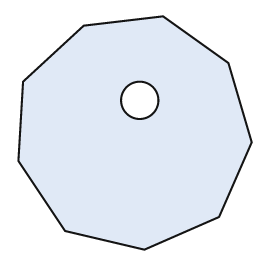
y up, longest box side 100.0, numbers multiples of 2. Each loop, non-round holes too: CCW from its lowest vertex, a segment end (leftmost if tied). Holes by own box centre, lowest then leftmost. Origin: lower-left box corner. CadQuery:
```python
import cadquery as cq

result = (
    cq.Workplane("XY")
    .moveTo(54.0, 0.0)
    .lineTo(86.0, 14.0)
    .lineTo(100.0, 46.0)
    .lineTo(90.0, 80.0)
    .lineTo(62.0, 100.0)
    .lineTo(28.0, 96.0)
    .lineTo(2.0, 72.0)
    .lineTo(0.0, 38.0)
    .lineTo(20.0, 8.0)
    .close()
    .moveTo(52.0, 64.0)
    .circle(8.0)
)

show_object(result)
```